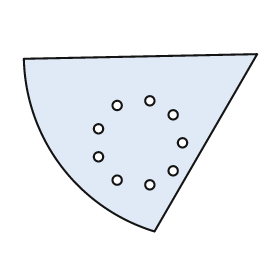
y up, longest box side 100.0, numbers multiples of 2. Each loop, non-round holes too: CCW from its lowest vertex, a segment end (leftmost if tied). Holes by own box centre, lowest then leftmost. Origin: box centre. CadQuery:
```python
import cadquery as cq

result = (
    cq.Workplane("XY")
    .moveTo(6.0, -38.0)
    .lineTo(50.0, 38.0)
    .lineTo(-50.0, 36.0)
    .threePointArc((-34.0, -10.0), (6.0, -38.0))
    .close()
    .moveTo(4.0, -18.0)
    .circle(2.0)
    .moveTo(-10.0, -16.0)
    .circle(2.0)
    .moveTo(14.0, -12.0)
    .circle(2.0)
    .moveTo(-18.0, -6.0)
    .circle(2.0)
    .moveTo(18.0, 0.0)
    .circle(2.0)
    .moveTo(-18.0, 6.0)
    .circle(2.0)
    .moveTo(14.0, 12.0)
    .circle(2.0)
    .moveTo(-10.0, 16.0)
    .circle(2.0)
    .moveTo(4.0, 18.0)
    .circle(2.0)
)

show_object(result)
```